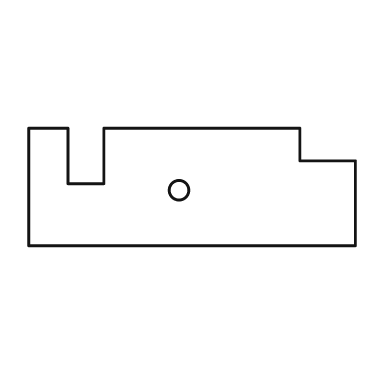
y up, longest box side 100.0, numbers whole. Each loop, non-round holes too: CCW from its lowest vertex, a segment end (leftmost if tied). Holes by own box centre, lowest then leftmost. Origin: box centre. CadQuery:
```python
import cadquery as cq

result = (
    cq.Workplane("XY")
    .moveTo(-50.0, -18.0)
    .lineTo(50.0, -18.0)
    .lineTo(50.0, 8.0)
    .lineTo(33.0, 8.0)
    .lineTo(33.0, 18.0)
    .lineTo(-27.0, 18.0)
    .lineTo(-27.0, 1.0)
    .lineTo(-38.0, 1.0)
    .lineTo(-38.0, 18.0)
    .lineTo(-50.0, 18.0)
    .close()
    .moveTo(-4.0, -1.0)
    .circle(3.0)
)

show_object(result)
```